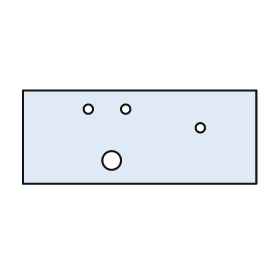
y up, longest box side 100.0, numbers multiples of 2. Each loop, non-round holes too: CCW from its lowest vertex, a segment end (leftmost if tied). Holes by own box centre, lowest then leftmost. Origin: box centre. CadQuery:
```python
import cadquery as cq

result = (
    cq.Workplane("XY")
    .moveTo(-50.0, -20.0)
    .lineTo(50.0, -20.0)
    .lineTo(50.0, 20.0)
    .lineTo(-50.0, 20.0)
    .close()
    .moveTo(-12.0, -10.0)
    .circle(4.0)
    .moveTo(26.0, 4.0)
    .circle(2.0)
    .moveTo(-22.0, 12.0)
    .circle(2.0)
    .moveTo(-6.0, 12.0)
    .circle(2.0)
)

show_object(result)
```